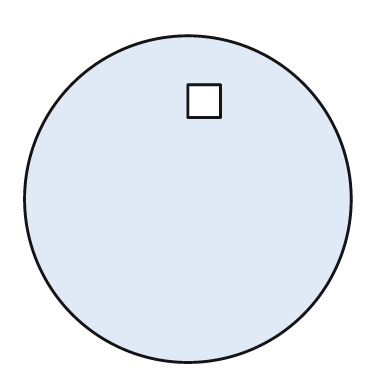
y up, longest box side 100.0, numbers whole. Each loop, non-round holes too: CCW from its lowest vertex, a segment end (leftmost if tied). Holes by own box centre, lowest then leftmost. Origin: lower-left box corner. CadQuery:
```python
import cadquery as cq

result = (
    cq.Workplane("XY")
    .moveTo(50.0, 50.0)
    .circle(50.0)
    .moveTo(50.0, 75.0)
    .lineTo(60.0, 75.0)
    .lineTo(60.0, 85.0)
    .lineTo(50.0, 85.0)
    .close()
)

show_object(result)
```